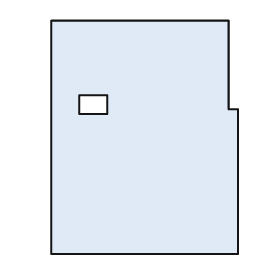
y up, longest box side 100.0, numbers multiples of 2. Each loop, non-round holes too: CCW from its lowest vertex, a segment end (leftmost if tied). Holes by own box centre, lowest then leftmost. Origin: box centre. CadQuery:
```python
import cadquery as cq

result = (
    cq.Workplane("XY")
    .moveTo(-40.0, -50.0)
    .lineTo(40.0, -50.0)
    .lineTo(40.0, 12.0)
    .lineTo(36.0, 12.0)
    .lineTo(36.0, 50.0)
    .lineTo(-40.0, 50.0)
    .close()
    .moveTo(-28.0, 10.0)
    .lineTo(-16.0, 10.0)
    .lineTo(-16.0, 18.0)
    .lineTo(-28.0, 18.0)
    .close()
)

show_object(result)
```